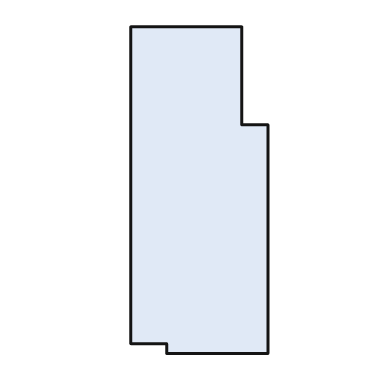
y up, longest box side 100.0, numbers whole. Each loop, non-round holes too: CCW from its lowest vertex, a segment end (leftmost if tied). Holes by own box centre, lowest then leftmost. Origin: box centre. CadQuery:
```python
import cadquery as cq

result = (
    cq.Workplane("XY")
    .moveTo(-10.0, -50.0)
    .lineTo(21.0, -50.0)
    .lineTo(21.0, 20.0)
    .lineTo(13.0, 20.0)
    .lineTo(13.0, 50.0)
    .lineTo(-21.0, 50.0)
    .lineTo(-21.0, -47.0)
    .lineTo(-10.0, -47.0)
    .close()
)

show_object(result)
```